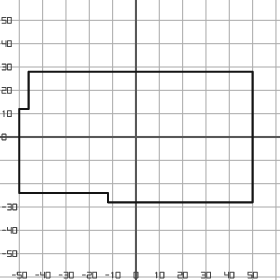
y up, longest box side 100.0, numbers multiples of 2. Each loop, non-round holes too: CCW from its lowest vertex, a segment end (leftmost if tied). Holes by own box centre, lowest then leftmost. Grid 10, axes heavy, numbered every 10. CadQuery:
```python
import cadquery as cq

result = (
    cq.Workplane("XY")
    .moveTo(-12.0, -28.0)
    .lineTo(50.0, -28.0)
    .lineTo(50.0, 28.0)
    .lineTo(-46.0, 28.0)
    .lineTo(-46.0, 12.0)
    .lineTo(-50.0, 12.0)
    .lineTo(-50.0, -24.0)
    .lineTo(-12.0, -24.0)
    .close()
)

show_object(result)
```